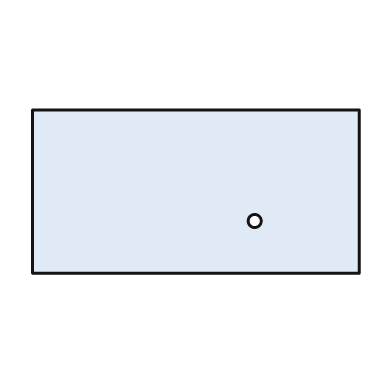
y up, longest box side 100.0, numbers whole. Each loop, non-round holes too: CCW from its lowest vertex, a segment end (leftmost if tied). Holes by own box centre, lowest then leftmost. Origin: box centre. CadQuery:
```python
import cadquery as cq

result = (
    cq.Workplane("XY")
    .moveTo(-50.0, -25.0)
    .lineTo(50.0, -25.0)
    .lineTo(50.0, 25.0)
    .lineTo(-50.0, 25.0)
    .close()
    .moveTo(18.0, -9.0)
    .circle(2.0)
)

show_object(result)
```